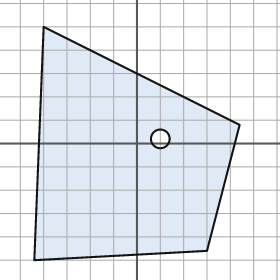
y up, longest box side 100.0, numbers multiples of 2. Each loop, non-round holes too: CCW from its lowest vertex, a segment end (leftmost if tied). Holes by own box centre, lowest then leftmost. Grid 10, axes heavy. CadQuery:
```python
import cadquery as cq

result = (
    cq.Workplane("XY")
    .moveTo(-44.0, -50.0)
    .lineTo(30.0, -46.0)
    .lineTo(44.0, 8.0)
    .lineTo(-40.0, 50.0)
    .close()
    .moveTo(10.0, 2.0)
    .circle(4.0)
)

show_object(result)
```